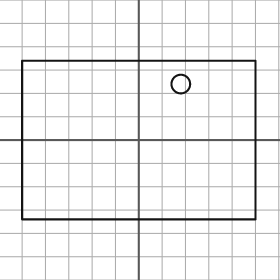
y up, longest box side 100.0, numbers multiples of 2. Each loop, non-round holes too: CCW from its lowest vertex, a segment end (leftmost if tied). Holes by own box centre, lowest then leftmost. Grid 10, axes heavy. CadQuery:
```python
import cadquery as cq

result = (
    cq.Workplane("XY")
    .moveTo(-50.0, -34.0)
    .lineTo(50.0, -34.0)
    .lineTo(50.0, 34.0)
    .lineTo(-50.0, 34.0)
    .close()
    .moveTo(18.0, 24.0)
    .circle(4.0)
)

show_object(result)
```